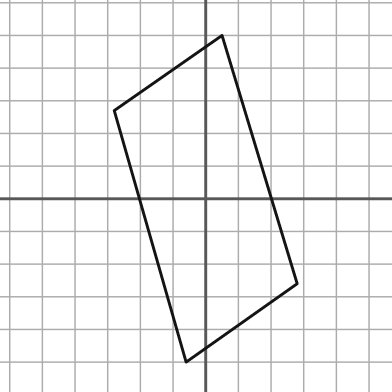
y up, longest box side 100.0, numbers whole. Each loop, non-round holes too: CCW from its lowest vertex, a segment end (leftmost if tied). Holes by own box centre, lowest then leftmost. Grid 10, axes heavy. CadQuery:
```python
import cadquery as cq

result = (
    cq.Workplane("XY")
    .moveTo(-6.0, -50.0)
    .lineTo(28.0, -26.0)
    .lineTo(5.0, 50.0)
    .lineTo(-28.0, 27.0)
    .close()
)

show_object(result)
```